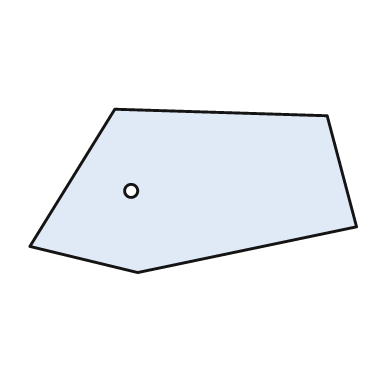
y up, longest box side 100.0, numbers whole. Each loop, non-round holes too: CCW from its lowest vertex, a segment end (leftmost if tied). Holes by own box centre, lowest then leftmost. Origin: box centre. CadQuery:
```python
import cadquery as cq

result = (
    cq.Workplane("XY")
    .moveTo(-17.0, -25.0)
    .lineTo(50.0, -11.0)
    .lineTo(41.0, 23.0)
    .lineTo(-24.0, 25.0)
    .lineTo(-50.0, -17.0)
    .close()
    .moveTo(-19.0, 0.0)
    .circle(2.0)
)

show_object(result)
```